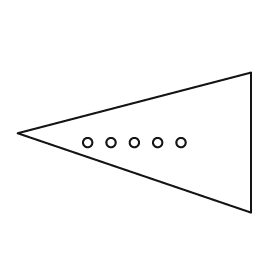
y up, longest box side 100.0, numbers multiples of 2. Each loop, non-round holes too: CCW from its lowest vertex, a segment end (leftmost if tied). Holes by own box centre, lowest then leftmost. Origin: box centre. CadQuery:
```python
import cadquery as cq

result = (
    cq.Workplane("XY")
    .moveTo(50.0, -30.0)
    .lineTo(50.0, 30.0)
    .lineTo(-50.0, 4.0)
    .close()
    .moveTo(-20.0, 0.0)
    .circle(2.0)
    .moveTo(-10.0, 0.0)
    .circle(2.0)
    .moveTo(0.0, 0.0)
    .circle(2.0)
    .moveTo(10.0, 0.0)
    .circle(2.0)
    .moveTo(20.0, 0.0)
    .circle(2.0)
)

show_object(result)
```